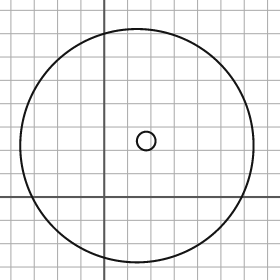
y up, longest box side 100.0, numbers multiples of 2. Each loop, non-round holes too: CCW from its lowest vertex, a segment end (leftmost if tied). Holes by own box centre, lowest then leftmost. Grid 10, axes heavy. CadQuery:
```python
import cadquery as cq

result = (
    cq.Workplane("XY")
    .moveTo(14.0, 22.0)
    .circle(50.0)
    .moveTo(18.0, 24.0)
    .circle(4.0)
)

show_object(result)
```